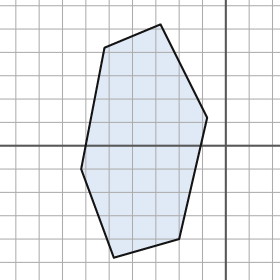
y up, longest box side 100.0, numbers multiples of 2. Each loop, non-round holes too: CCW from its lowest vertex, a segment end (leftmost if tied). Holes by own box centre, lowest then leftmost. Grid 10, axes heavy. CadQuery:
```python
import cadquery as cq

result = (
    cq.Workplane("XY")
    .moveTo(-48.0, -48.0)
    .lineTo(-20.0, -40.0)
    .lineTo(-8.0, 12.0)
    .lineTo(-28.0, 52.0)
    .lineTo(-52.0, 42.0)
    .lineTo(-62.0, -10.0)
    .close()
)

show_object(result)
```